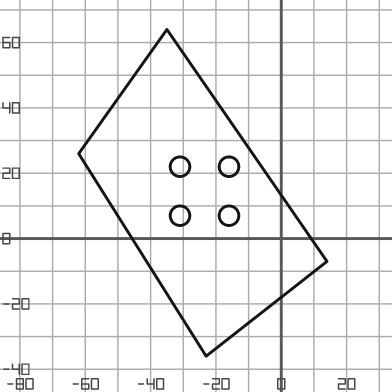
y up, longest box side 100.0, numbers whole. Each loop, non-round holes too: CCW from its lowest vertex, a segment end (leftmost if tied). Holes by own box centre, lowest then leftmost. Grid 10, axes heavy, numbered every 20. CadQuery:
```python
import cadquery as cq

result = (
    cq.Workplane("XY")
    .moveTo(-23.0, -36.0)
    .lineTo(14.0, -7.0)
    .lineTo(-35.0, 64.0)
    .lineTo(-62.0, 26.0)
    .close()
    .moveTo(-31.0, 7.0)
    .circle(3.0)
    .moveTo(-16.0, 7.0)
    .circle(3.0)
    .moveTo(-31.0, 22.0)
    .circle(3.0)
    .moveTo(-16.0, 22.0)
    .circle(3.0)
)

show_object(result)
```